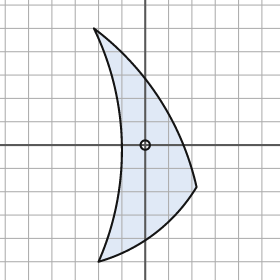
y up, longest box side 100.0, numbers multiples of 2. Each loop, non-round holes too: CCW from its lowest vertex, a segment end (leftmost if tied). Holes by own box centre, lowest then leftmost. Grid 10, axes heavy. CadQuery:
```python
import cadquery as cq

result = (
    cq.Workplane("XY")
    .moveTo(-20.0, -50.0)
    .threePointArc((4.0, -38.0), (22.0, -18.0))
    .threePointArc((6.0, 20.0), (-22.0, 50.0))
    .threePointArc((-10.0, 0.0), (-20.0, -50.0))
    .close()
    .moveTo(0.0, 0.0)
    .circle(2.0)
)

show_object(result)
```